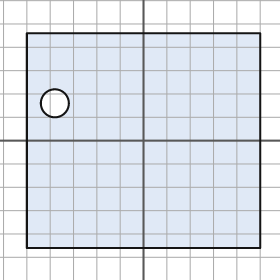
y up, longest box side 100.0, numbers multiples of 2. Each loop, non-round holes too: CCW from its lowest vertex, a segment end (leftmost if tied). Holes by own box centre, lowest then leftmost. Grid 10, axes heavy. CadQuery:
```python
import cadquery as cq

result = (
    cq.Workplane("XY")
    .moveTo(-50.0, -46.0)
    .lineTo(50.0, -46.0)
    .lineTo(50.0, 46.0)
    .lineTo(-50.0, 46.0)
    .close()
    .moveTo(-38.0, 16.0)
    .circle(6.0)
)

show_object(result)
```